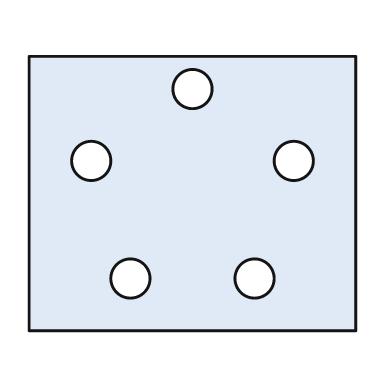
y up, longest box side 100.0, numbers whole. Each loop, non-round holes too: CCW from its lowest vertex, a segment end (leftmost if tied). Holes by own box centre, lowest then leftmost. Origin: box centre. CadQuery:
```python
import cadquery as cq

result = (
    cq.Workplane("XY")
    .moveTo(-50.0, -42.0)
    .lineTo(50.0, -42.0)
    .lineTo(50.0, 42.0)
    .lineTo(-50.0, 42.0)
    .close()
    .moveTo(-19.0, -26.0)
    .circle(6.0)
    .moveTo(19.0, -26.0)
    .circle(6.0)
    .moveTo(-31.0, 10.0)
    .circle(6.0)
    .moveTo(31.0, 10.0)
    .circle(6.0)
    .moveTo(0.0, 32.0)
    .circle(6.0)
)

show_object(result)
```